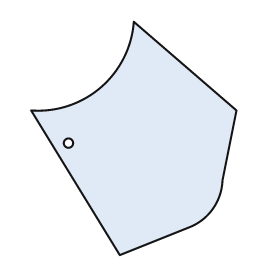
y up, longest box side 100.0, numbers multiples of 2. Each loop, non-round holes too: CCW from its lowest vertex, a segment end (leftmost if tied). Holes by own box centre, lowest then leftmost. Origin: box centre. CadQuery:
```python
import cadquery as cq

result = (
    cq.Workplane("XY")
    .moveTo(-6.0, -50.0)
    .lineTo(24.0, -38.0)
    .threePointArc((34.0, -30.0), (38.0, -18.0))
    .lineTo(44.0, 12.0)
    .lineTo(0.0, 50.0)
    .threePointArc((-14.0, 22.0), (-44.0, 12.0))
    .close()
    .moveTo(-28.0, -2.0)
    .circle(2.0)
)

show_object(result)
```